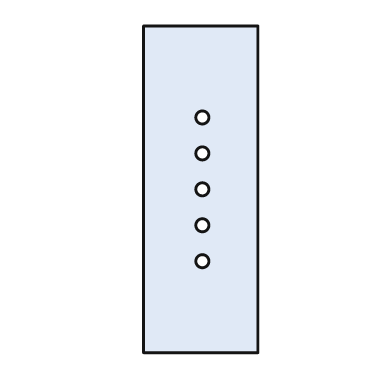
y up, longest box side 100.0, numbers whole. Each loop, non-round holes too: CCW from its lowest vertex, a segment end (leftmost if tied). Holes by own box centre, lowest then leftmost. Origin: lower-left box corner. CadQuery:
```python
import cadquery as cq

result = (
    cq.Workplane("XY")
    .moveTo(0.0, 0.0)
    .lineTo(35.0, 0.0)
    .lineTo(35.0, 100.0)
    .lineTo(0.0, 100.0)
    .close()
    .moveTo(18.0, 28.0)
    .circle(2.0)
    .moveTo(18.0, 39.0)
    .circle(2.0)
    .moveTo(18.0, 50.0)
    .circle(2.0)
    .moveTo(18.0, 61.0)
    .circle(2.0)
    .moveTo(18.0, 72.0)
    .circle(2.0)
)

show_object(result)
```